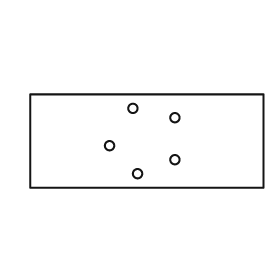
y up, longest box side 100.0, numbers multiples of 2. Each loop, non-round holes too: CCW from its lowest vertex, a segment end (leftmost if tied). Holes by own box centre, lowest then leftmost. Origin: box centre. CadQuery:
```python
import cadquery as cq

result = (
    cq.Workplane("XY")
    .moveTo(-50.0, -20.0)
    .lineTo(50.0, -20.0)
    .lineTo(50.0, 20.0)
    .lineTo(-50.0, 20.0)
    .close()
    .moveTo(-4.0, -14.0)
    .circle(2.0)
    .moveTo(12.0, -8.0)
    .circle(2.0)
    .moveTo(-16.0, -2.0)
    .circle(2.0)
    .moveTo(12.0, 10.0)
    .circle(2.0)
    .moveTo(-6.0, 14.0)
    .circle(2.0)
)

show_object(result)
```